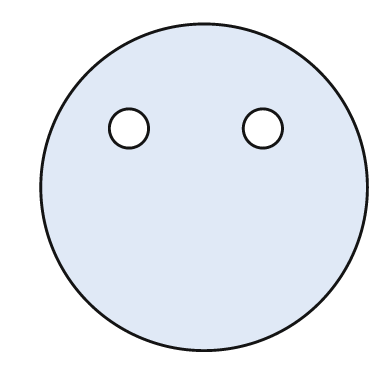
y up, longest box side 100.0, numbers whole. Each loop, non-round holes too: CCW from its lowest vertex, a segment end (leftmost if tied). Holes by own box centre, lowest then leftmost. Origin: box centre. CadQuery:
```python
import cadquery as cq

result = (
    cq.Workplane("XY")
    .moveTo(0.0, 0.0)
    .circle(50.0)
    .moveTo(-23.0, 18.0)
    .circle(6.0)
    .moveTo(18.0, 18.0)
    .circle(6.0)
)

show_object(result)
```